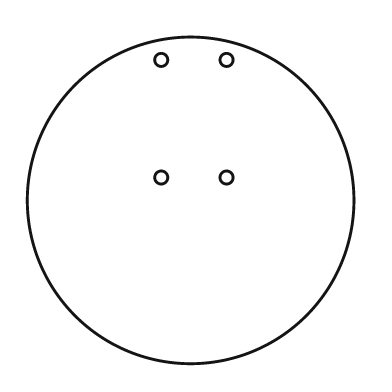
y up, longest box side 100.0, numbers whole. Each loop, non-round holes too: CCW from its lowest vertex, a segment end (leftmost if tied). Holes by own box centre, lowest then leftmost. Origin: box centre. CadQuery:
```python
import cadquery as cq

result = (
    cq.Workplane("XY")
    .moveTo(0.0, 0.0)
    .circle(50.0)
    .moveTo(-9.0, 7.0)
    .circle(2.0)
    .moveTo(11.0, 7.0)
    .circle(2.0)
    .moveTo(-9.0, 43.0)
    .circle(2.0)
    .moveTo(11.0, 43.0)
    .circle(2.0)
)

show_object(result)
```